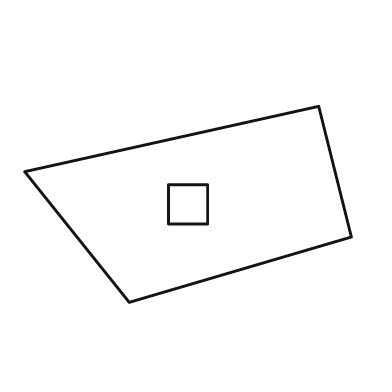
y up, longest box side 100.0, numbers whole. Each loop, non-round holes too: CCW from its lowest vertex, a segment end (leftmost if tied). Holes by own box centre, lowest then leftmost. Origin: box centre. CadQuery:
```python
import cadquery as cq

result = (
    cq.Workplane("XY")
    .moveTo(-18.0, -30.0)
    .lineTo(50.0, -10.0)
    .lineTo(40.0, 30.0)
    .lineTo(-50.0, 10.0)
    .close()
    .moveTo(-6.0, -6.0)
    .lineTo(6.0, -6.0)
    .lineTo(6.0, 6.0)
    .lineTo(-6.0, 6.0)
    .close()
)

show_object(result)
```